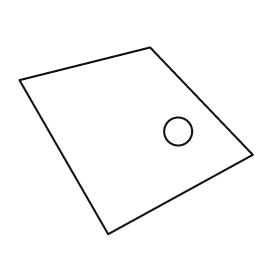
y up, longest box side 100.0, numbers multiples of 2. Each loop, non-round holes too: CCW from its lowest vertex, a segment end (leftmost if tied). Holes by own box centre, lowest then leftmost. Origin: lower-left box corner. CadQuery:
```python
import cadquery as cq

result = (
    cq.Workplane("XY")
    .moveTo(38.0, 0.0)
    .lineTo(100.0, 34.0)
    .lineTo(56.0, 80.0)
    .lineTo(0.0, 66.0)
    .close()
    .moveTo(68.0, 44.0)
    .circle(6.0)
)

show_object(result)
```